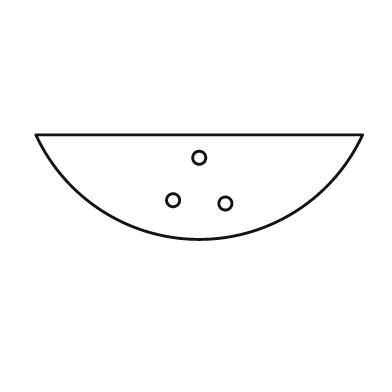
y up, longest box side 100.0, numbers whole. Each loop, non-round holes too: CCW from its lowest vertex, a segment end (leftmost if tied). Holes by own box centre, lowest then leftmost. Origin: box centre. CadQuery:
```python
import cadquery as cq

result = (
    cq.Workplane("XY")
    .moveTo(-50.0, 16.0)
    .threePointArc((0.0, -16.0), (50.0, 16.0))
    .close()
    .moveTo(8.0, -5.0)
    .circle(2.0)
    .moveTo(-8.0, -4.0)
    .circle(2.0)
    .moveTo(0.0, 9.0)
    .circle(2.0)
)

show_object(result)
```